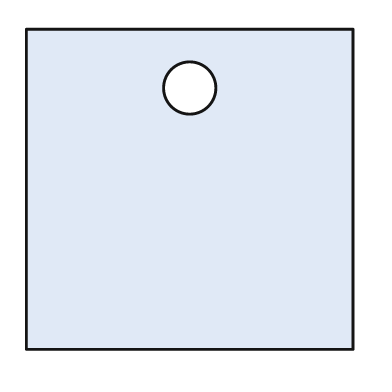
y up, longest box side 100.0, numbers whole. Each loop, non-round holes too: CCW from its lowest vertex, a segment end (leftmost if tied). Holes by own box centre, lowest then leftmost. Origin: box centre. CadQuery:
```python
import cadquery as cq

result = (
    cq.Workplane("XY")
    .moveTo(-50.0, -49.0)
    .lineTo(50.0, -49.0)
    .lineTo(50.0, 49.0)
    .lineTo(-50.0, 49.0)
    .close()
    .moveTo(0.0, 31.0)
    .circle(8.0)
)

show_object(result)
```